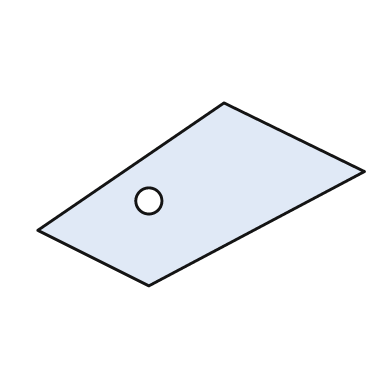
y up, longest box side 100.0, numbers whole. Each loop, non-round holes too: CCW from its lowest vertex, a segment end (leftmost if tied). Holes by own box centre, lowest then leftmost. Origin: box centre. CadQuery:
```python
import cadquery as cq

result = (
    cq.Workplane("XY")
    .moveTo(-16.0, -28.0)
    .lineTo(50.0, 7.0)
    .lineTo(7.0, 28.0)
    .lineTo(-50.0, -11.0)
    .close()
    .moveTo(-16.0, -2.0)
    .circle(4.0)
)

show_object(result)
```